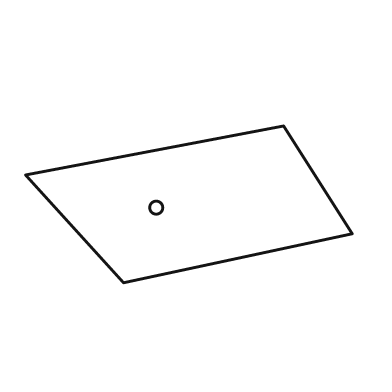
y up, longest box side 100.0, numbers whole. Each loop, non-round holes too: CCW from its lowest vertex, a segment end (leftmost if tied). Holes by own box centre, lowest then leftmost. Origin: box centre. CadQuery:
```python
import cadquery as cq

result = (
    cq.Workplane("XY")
    .moveTo(-20.0, -24.0)
    .lineTo(50.0, -9.0)
    .lineTo(29.0, 24.0)
    .lineTo(-50.0, 9.0)
    .close()
    .moveTo(-10.0, -1.0)
    .circle(2.0)
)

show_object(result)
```